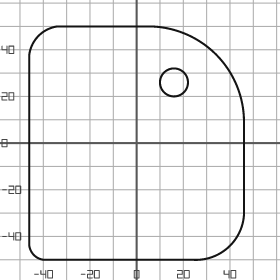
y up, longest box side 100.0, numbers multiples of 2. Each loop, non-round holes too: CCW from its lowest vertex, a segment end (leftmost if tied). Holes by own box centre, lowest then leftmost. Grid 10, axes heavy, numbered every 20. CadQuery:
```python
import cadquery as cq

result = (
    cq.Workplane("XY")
    .moveTo(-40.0, -50.0)
    .lineTo(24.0, -50.0)
    .threePointArc((40.0, -44.0), (46.0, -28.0))
    .lineTo(46.0, 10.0)
    .threePointArc((34.0, 38.0), (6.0, 50.0))
    .lineTo(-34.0, 50.0)
    .threePointArc((-42.0, 46.0), (-46.0, 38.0))
    .lineTo(-46.0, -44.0)
    .threePointArc((-44.0, -48.0), (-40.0, -50.0))
    .close()
    .moveTo(16.0, 26.0)
    .circle(6.0)
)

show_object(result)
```